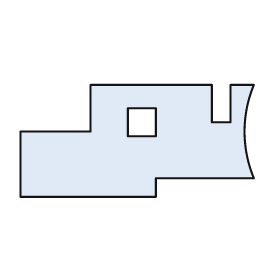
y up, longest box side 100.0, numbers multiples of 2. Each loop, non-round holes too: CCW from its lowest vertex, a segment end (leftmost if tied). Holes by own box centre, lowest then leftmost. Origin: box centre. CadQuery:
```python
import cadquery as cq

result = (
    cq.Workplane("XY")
    .moveTo(-50.0, -24.0)
    .lineTo(8.0, -24.0)
    .lineTo(8.0, -16.0)
    .lineTo(50.0, -16.0)
    .threePointArc((46.0, 4.0), (50.0, 24.0))
    .lineTo(40.0, 24.0)
    .lineTo(40.0, 8.0)
    .lineTo(32.0, 8.0)
    .lineTo(32.0, 24.0)
    .lineTo(-20.0, 24.0)
    .lineTo(-20.0, 4.0)
    .lineTo(-50.0, 4.0)
    .close()
    .moveTo(-4.0, 2.0)
    .lineTo(8.0, 2.0)
    .lineTo(8.0, 14.0)
    .lineTo(-4.0, 14.0)
    .close()
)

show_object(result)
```